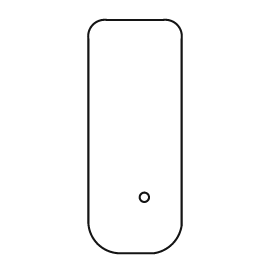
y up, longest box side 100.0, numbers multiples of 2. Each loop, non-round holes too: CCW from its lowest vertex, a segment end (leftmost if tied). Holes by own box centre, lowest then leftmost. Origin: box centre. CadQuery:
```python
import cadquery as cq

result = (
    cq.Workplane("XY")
    .moveTo(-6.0, -50.0)
    .lineTo(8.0, -50.0)
    .threePointArc((16.0, -46.0), (20.0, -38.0))
    .lineTo(20.0, 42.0)
    .threePointArc((18.0, 48.0), (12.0, 50.0))
    .lineTo(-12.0, 50.0)
    .threePointArc((-18.0, 48.0), (-20.0, 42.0))
    .lineTo(-20.0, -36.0)
    .threePointArc((-16.0, -46.0), (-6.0, -50.0))
    .close()
    .moveTo(4.0, -26.0)
    .circle(2.0)
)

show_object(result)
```